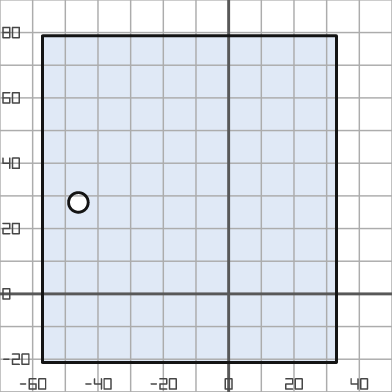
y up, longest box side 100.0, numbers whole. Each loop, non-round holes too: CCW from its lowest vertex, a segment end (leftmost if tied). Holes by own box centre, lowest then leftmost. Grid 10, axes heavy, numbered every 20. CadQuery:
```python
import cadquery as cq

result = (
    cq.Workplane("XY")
    .moveTo(-57.0, -21.0)
    .lineTo(33.0, -21.0)
    .lineTo(33.0, 79.0)
    .lineTo(-57.0, 79.0)
    .close()
    .moveTo(-46.0, 28.0)
    .circle(3.0)
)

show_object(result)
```